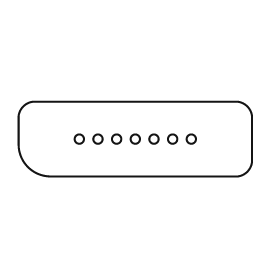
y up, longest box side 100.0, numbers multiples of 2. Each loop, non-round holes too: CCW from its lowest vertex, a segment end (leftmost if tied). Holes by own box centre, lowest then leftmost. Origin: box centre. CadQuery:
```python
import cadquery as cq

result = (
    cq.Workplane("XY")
    .moveTo(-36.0, -16.0)
    .lineTo(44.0, -16.0)
    .threePointArc((48.0, -14.0), (50.0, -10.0))
    .lineTo(50.0, 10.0)
    .threePointArc((48.0, 14.0), (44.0, 16.0))
    .lineTo(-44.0, 16.0)
    .threePointArc((-48.0, 14.0), (-50.0, 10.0))
    .lineTo(-50.0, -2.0)
    .threePointArc((-46.0, -12.0), (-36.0, -16.0))
    .close()
    .moveTo(-24.0, 0.0)
    .circle(2.0)
    .moveTo(-16.0, 0.0)
    .circle(2.0)
    .moveTo(-8.0, 0.0)
    .circle(2.0)
    .moveTo(0.0, 0.0)
    .circle(2.0)
    .moveTo(8.0, 0.0)
    .circle(2.0)
    .moveTo(16.0, 0.0)
    .circle(2.0)
    .moveTo(24.0, 0.0)
    .circle(2.0)
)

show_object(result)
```